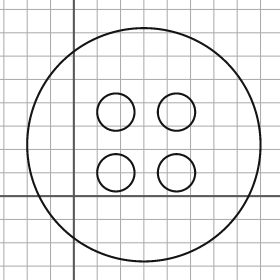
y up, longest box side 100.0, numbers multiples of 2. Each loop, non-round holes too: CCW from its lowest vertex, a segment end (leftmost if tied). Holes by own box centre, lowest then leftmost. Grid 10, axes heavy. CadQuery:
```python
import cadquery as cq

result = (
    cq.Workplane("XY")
    .moveTo(30.0, 22.0)
    .circle(50.0)
    .moveTo(18.0, 10.0)
    .circle(8.0)
    .moveTo(44.0, 10.0)
    .circle(8.0)
    .moveTo(18.0, 36.0)
    .circle(8.0)
    .moveTo(44.0, 36.0)
    .circle(8.0)
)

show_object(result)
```